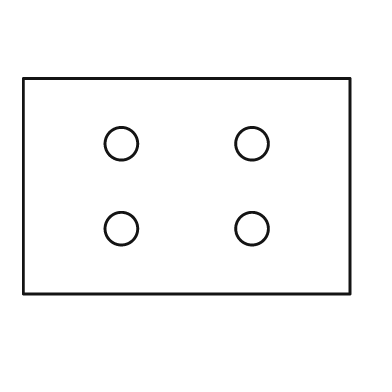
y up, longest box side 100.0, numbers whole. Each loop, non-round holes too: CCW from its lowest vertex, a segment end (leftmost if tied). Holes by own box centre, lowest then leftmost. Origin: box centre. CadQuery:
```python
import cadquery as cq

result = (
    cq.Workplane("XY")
    .moveTo(-50.0, -33.0)
    .lineTo(50.0, -33.0)
    .lineTo(50.0, 33.0)
    .lineTo(-50.0, 33.0)
    .close()
    .moveTo(-20.0, -13.0)
    .circle(5.0)
    .moveTo(20.0, -13.0)
    .circle(5.0)
    .moveTo(-20.0, 13.0)
    .circle(5.0)
    .moveTo(20.0, 13.0)
    .circle(5.0)
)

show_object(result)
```